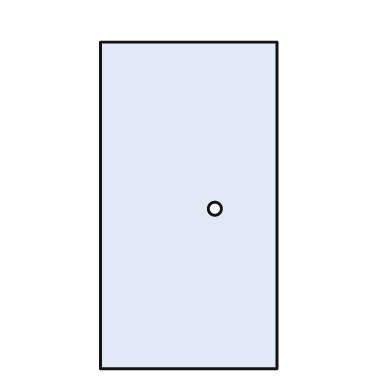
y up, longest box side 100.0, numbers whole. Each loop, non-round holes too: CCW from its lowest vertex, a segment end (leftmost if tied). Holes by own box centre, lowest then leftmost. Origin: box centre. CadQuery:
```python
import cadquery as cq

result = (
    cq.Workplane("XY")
    .moveTo(-27.0, -50.0)
    .lineTo(27.0, -50.0)
    .lineTo(27.0, 50.0)
    .lineTo(-27.0, 50.0)
    .close()
    .moveTo(8.0, -1.0)
    .circle(2.0)
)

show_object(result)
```